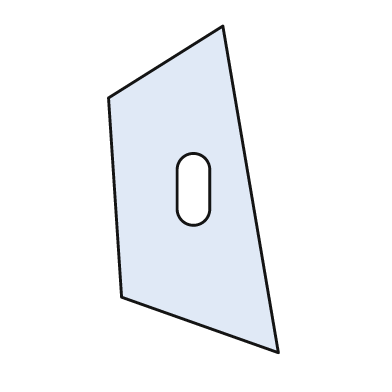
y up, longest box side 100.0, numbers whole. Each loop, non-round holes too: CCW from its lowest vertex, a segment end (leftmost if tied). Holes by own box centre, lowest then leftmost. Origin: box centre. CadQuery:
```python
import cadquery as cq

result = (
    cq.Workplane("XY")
    .moveTo(26.0, -50.0)
    .lineTo(9.0, 50.0)
    .lineTo(-26.0, 28.0)
    .lineTo(-22.0, -33.0)
    .close()
    .moveTo(-5.0, -6.0)
    .threePointArc((0.0, -11.0), (5.0, -6.0))
    .lineTo(5.0, 6.0)
    .threePointArc((0.0, 11.0), (-5.0, 6.0))
    .close()
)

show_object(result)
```